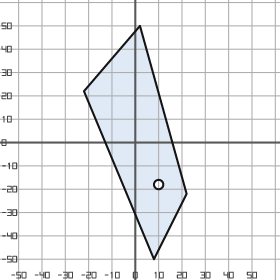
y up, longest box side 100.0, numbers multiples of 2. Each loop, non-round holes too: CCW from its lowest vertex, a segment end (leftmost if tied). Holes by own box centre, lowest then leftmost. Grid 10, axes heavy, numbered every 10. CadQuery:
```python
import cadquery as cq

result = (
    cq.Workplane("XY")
    .moveTo(8.0, -50.0)
    .lineTo(22.0, -22.0)
    .lineTo(2.0, 50.0)
    .lineTo(-22.0, 22.0)
    .close()
    .moveTo(10.0, -18.0)
    .circle(2.0)
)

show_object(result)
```